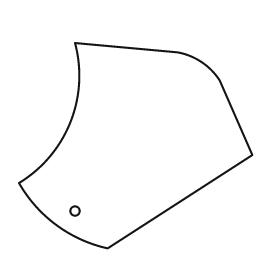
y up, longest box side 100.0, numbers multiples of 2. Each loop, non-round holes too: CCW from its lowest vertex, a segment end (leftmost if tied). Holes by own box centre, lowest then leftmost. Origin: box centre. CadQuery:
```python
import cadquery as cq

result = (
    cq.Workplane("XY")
    .moveTo(-12.0, -44.0)
    .lineTo(50.0, -4.0)
    .lineTo(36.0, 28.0)
    .threePointArc((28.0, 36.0), (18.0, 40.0))
    .lineTo(-26.0, 44.0)
    .threePointArc((-28.0, 10.0), (-50.0, -16.0))
    .threePointArc((-34.0, -34.0), (-12.0, -44.0))
    .close()
    .moveTo(-26.0, -28.0)
    .circle(2.0)
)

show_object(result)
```